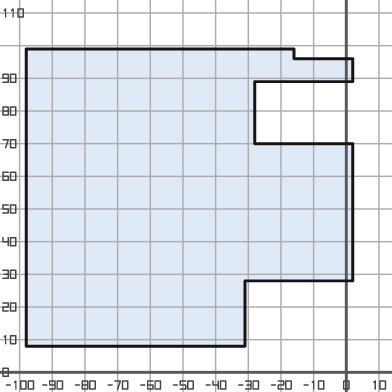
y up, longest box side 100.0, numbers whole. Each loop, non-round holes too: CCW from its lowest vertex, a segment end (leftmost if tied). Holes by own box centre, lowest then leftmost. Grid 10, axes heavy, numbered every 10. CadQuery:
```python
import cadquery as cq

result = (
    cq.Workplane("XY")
    .moveTo(-98.0, 8.0)
    .lineTo(-31.0, 8.0)
    .lineTo(-31.0, 28.0)
    .lineTo(2.0, 28.0)
    .lineTo(2.0, 70.0)
    .lineTo(-28.0, 70.0)
    .lineTo(-28.0, 89.0)
    .lineTo(2.0, 89.0)
    .lineTo(2.0, 96.0)
    .lineTo(-16.0, 96.0)
    .lineTo(-16.0, 99.0)
    .lineTo(-98.0, 99.0)
    .close()
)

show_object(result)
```